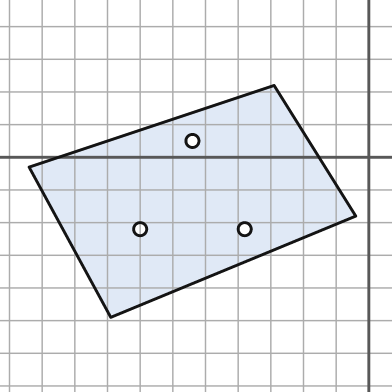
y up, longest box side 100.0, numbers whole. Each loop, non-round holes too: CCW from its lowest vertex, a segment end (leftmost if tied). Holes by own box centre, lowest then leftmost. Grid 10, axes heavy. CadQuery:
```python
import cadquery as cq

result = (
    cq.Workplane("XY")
    .moveTo(-79.0, -49.0)
    .lineTo(-4.0, -18.0)
    .lineTo(-29.0, 22.0)
    .lineTo(-104.0, -3.0)
    .close()
    .moveTo(-70.0, -22.0)
    .circle(2.0)
    .moveTo(-38.0, -22.0)
    .circle(2.0)
    .moveTo(-54.0, 5.0)
    .circle(2.0)
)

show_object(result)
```